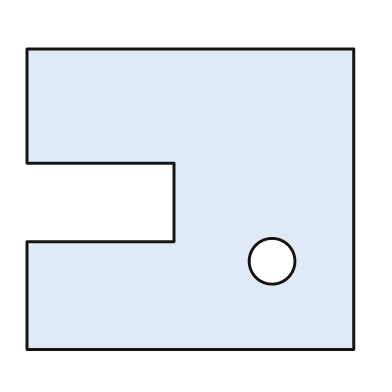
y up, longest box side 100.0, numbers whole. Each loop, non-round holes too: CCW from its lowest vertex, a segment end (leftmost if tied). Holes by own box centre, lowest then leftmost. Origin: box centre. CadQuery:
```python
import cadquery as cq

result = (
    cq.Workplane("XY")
    .moveTo(-50.0, -46.0)
    .lineTo(50.0, -46.0)
    .lineTo(50.0, 46.0)
    .lineTo(-50.0, 46.0)
    .lineTo(-50.0, 11.0)
    .lineTo(-5.0, 11.0)
    .lineTo(-5.0, -13.0)
    .lineTo(-50.0, -13.0)
    .close()
    .moveTo(25.0, -19.0)
    .circle(7.0)
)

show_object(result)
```